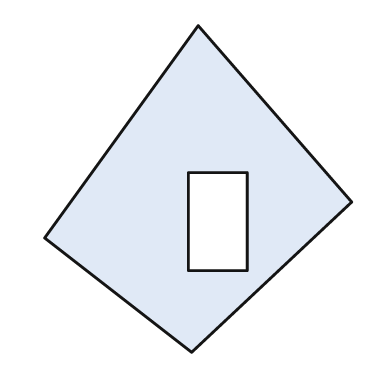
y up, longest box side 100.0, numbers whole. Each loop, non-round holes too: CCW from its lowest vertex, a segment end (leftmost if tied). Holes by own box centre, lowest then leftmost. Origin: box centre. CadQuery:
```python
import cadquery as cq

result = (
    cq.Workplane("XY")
    .moveTo(-2.0, -50.0)
    .lineTo(47.0, -4.0)
    .lineTo(0.0, 50.0)
    .lineTo(-47.0, -15.0)
    .close()
    .moveTo(-3.0, -25.0)
    .lineTo(15.0, -25.0)
    .lineTo(15.0, 5.0)
    .lineTo(-3.0, 5.0)
    .close()
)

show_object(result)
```